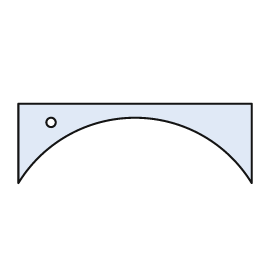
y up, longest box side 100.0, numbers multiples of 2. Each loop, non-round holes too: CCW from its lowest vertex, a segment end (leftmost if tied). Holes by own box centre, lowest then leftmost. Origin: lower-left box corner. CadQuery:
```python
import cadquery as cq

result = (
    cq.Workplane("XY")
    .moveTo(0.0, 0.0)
    .threePointArc((50.0, 28.0), (100.0, 0.0))
    .lineTo(100.0, 34.0)
    .lineTo(0.0, 34.0)
    .close()
    .moveTo(14.0, 26.0)
    .circle(2.0)
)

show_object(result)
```